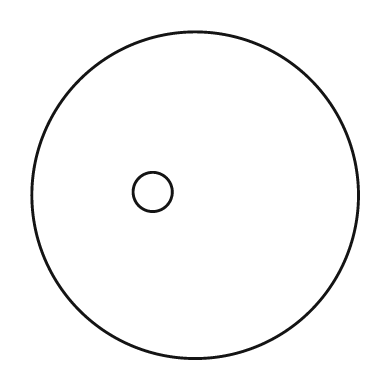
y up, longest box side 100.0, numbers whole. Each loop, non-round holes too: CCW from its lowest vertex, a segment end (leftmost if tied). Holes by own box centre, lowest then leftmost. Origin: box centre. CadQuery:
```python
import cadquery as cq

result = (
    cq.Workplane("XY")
    .moveTo(0.0, 0.0)
    .circle(50.0)
    .moveTo(-13.0, 1.0)
    .circle(6.0)
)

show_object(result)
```